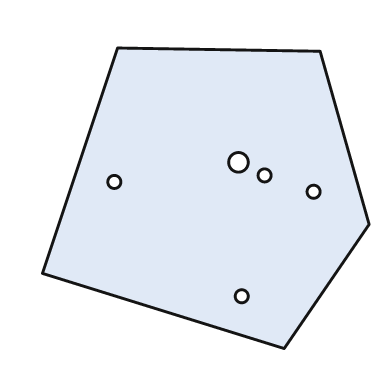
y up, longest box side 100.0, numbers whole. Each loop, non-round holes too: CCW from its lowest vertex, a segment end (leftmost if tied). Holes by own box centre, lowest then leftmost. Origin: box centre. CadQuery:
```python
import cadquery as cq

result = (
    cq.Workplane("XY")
    .moveTo(24.0, -46.0)
    .lineTo(50.0, -8.0)
    .lineTo(35.0, 45.0)
    .lineTo(-27.0, 46.0)
    .lineTo(-50.0, -23.0)
    .close()
    .moveTo(11.0, -30.0)
    .circle(2.0)
    .moveTo(33.0, 2.0)
    .circle(2.0)
    .moveTo(-28.0, 5.0)
    .circle(2.0)
    .moveTo(18.0, 7.0)
    .circle(2.0)
    .moveTo(10.0, 11.0)
    .circle(3.0)
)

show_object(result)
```